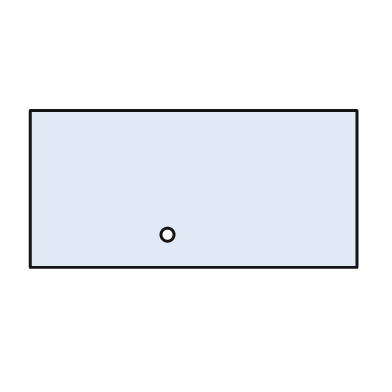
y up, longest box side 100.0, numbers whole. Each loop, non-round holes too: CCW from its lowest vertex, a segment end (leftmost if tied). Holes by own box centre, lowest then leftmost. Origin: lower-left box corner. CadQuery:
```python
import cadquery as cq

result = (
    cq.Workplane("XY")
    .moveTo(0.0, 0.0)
    .lineTo(100.0, 0.0)
    .lineTo(100.0, 48.0)
    .lineTo(0.0, 48.0)
    .close()
    .moveTo(42.0, 10.0)
    .circle(2.0)
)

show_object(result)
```